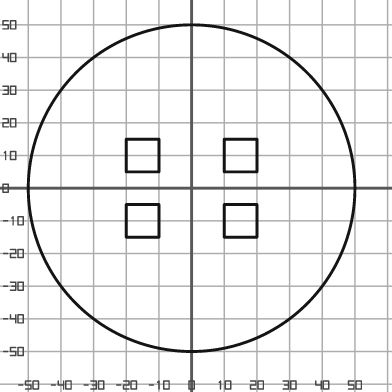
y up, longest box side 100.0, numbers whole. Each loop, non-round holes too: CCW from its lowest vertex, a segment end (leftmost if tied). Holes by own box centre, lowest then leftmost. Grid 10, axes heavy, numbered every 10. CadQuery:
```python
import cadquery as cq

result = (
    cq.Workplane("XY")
    .moveTo(0.0, 0.0)
    .circle(50.0)
    .moveTo(-20.0, -15.0)
    .lineTo(-10.0, -15.0)
    .lineTo(-10.0, -5.0)
    .lineTo(-20.0, -5.0)
    .close()
    .moveTo(10.0, -15.0)
    .lineTo(20.0, -15.0)
    .lineTo(20.0, -5.0)
    .lineTo(10.0, -5.0)
    .close()
    .moveTo(-20.0, 5.0)
    .lineTo(-10.0, 5.0)
    .lineTo(-10.0, 15.0)
    .lineTo(-20.0, 15.0)
    .close()
    .moveTo(10.0, 5.0)
    .lineTo(20.0, 5.0)
    .lineTo(20.0, 15.0)
    .lineTo(10.0, 15.0)
    .close()
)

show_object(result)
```